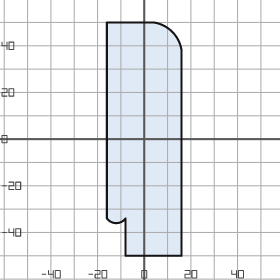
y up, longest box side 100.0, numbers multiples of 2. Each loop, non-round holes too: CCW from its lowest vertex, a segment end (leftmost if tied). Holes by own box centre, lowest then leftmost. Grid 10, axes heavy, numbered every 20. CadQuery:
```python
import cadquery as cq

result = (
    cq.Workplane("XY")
    .moveTo(-8.0, -50.0)
    .lineTo(16.0, -50.0)
    .lineTo(16.0, 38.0)
    .threePointArc((12.0, 46.0), (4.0, 50.0))
    .lineTo(-16.0, 50.0)
    .lineTo(-16.0, -34.0)
    .threePointArc((-12.0, -36.0), (-8.0, -34.0))
    .close()
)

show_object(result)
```